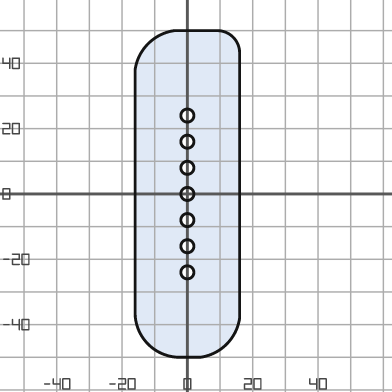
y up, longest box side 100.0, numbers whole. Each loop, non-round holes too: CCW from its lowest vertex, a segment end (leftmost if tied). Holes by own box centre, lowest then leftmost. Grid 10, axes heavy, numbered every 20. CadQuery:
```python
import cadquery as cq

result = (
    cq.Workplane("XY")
    .moveTo(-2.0, -50.0)
    .lineTo(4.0, -50.0)
    .threePointArc((12.0, -46.0), (16.0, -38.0))
    .lineTo(16.0, 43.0)
    .threePointArc((14.0, 48.0), (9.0, 50.0))
    .lineTo(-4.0, 50.0)
    .threePointArc((-12.0, 46.0), (-16.0, 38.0))
    .lineTo(-16.0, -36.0)
    .threePointArc((-12.0, -46.0), (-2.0, -50.0))
    .close()
    .moveTo(0.0, -24.0)
    .circle(2.0)
    .moveTo(0.0, -16.0)
    .circle(2.0)
    .moveTo(0.0, -8.0)
    .circle(2.0)
    .moveTo(0.0, 0.0)
    .circle(2.0)
    .moveTo(0.0, 8.0)
    .circle(2.0)
    .moveTo(0.0, 16.0)
    .circle(2.0)
    .moveTo(0.0, 24.0)
    .circle(2.0)
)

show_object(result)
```